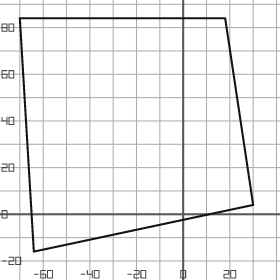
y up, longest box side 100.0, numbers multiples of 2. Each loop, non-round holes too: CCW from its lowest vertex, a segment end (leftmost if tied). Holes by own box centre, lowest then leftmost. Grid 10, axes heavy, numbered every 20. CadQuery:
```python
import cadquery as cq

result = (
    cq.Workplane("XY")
    .moveTo(-64.0, -16.0)
    .lineTo(30.0, 4.0)
    .lineTo(18.0, 84.0)
    .lineTo(-70.0, 84.0)
    .close()
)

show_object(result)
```